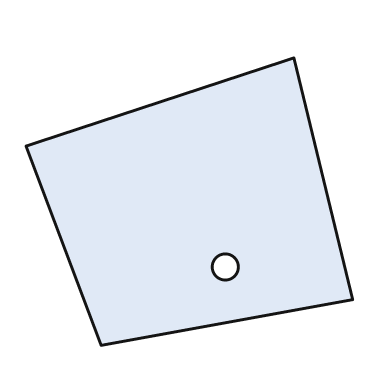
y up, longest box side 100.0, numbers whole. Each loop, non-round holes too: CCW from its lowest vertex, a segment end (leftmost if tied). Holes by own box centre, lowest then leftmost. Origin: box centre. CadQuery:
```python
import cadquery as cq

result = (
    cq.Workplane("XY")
    .moveTo(-27.0, -44.0)
    .lineTo(50.0, -30.0)
    .lineTo(32.0, 44.0)
    .lineTo(-50.0, 17.0)
    .close()
    .moveTo(11.0, -20.0)
    .circle(4.0)
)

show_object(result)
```